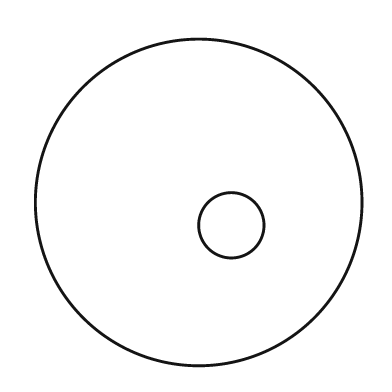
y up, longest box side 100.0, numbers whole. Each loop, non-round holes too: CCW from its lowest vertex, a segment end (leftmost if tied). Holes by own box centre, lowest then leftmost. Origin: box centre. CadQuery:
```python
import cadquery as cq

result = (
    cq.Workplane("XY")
    .moveTo(0.0, 0.0)
    .circle(50.0)
    .moveTo(10.0, -7.0)
    .circle(10.0)
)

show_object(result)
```